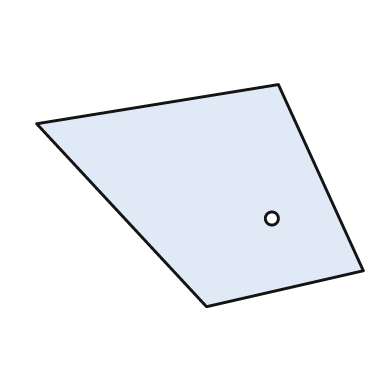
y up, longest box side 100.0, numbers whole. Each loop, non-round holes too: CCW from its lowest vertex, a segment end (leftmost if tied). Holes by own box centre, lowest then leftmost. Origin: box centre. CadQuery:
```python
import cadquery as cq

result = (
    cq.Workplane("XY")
    .moveTo(2.0, -34.0)
    .lineTo(50.0, -23.0)
    .lineTo(24.0, 34.0)
    .lineTo(-50.0, 22.0)
    .close()
    .moveTo(22.0, -7.0)
    .circle(2.0)
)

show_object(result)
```